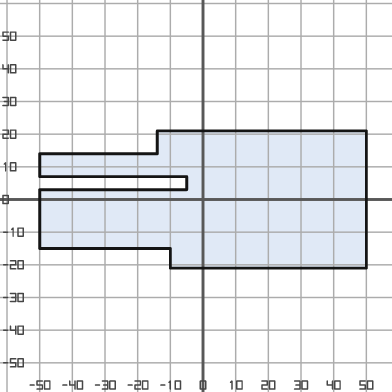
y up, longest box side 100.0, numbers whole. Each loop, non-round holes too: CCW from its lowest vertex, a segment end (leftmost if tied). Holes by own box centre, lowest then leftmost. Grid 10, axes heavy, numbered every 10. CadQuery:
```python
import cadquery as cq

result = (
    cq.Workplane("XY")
    .moveTo(-10.0, -21.0)
    .lineTo(50.0, -21.0)
    .lineTo(50.0, 21.0)
    .lineTo(-14.0, 21.0)
    .lineTo(-14.0, 14.0)
    .lineTo(-50.0, 14.0)
    .lineTo(-50.0, 7.0)
    .lineTo(-5.0, 7.0)
    .lineTo(-5.0, 3.0)
    .lineTo(-50.0, 3.0)
    .lineTo(-50.0, -15.0)
    .lineTo(-10.0, -15.0)
    .close()
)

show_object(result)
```